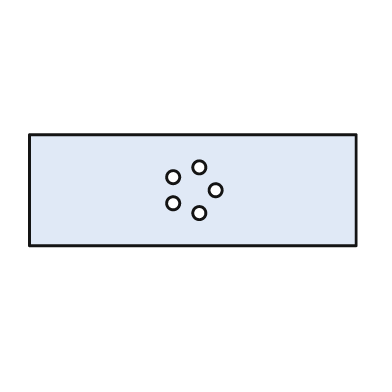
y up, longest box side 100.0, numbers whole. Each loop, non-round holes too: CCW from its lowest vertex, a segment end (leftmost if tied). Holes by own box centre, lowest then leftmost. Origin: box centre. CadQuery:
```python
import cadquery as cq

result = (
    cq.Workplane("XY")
    .moveTo(-50.0, -17.0)
    .lineTo(50.0, -17.0)
    .lineTo(50.0, 17.0)
    .lineTo(-50.0, 17.0)
    .close()
    .moveTo(2.0, -7.0)
    .circle(2.0)
    .moveTo(-6.0, -4.0)
    .circle(2.0)
    .moveTo(7.0, 0.0)
    .circle(2.0)
    .moveTo(-6.0, 4.0)
    .circle(2.0)
    .moveTo(2.0, 7.0)
    .circle(2.0)
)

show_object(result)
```